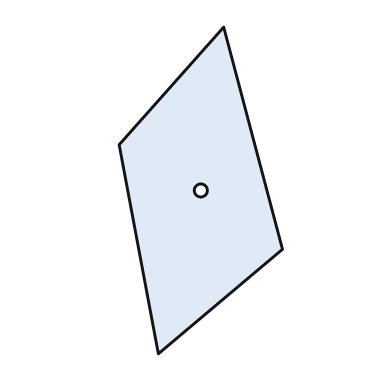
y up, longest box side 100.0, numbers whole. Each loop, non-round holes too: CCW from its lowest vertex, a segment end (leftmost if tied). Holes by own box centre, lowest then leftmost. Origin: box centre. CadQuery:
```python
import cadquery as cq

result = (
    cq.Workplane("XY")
    .moveTo(-13.0, -50.0)
    .lineTo(25.0, -18.0)
    .lineTo(7.0, 50.0)
    .lineTo(-25.0, 14.0)
    .close()
    .moveTo(0.0, 0.0)
    .circle(2.0)
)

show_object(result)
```